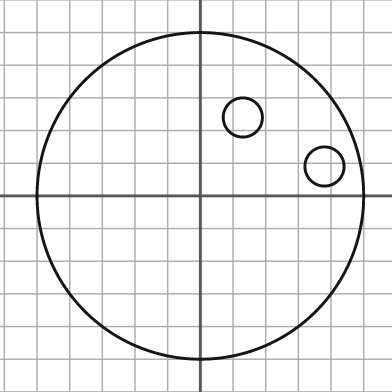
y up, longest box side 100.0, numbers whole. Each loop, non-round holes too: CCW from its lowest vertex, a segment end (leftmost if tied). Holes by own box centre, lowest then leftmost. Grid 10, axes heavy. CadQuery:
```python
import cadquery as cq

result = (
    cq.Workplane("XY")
    .moveTo(0.0, 0.0)
    .circle(50.0)
    .moveTo(38.0, 9.0)
    .circle(6.0)
    .moveTo(13.0, 24.0)
    .circle(6.0)
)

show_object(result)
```